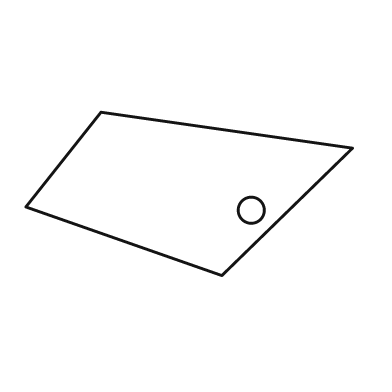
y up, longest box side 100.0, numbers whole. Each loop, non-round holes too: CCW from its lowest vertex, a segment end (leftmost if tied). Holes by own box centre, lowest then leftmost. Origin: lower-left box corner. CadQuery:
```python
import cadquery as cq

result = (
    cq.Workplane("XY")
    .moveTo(60.0, 0.0)
    .lineTo(100.0, 39.0)
    .lineTo(23.0, 50.0)
    .lineTo(0.0, 21.0)
    .close()
    .moveTo(69.0, 20.0)
    .circle(4.0)
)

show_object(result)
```